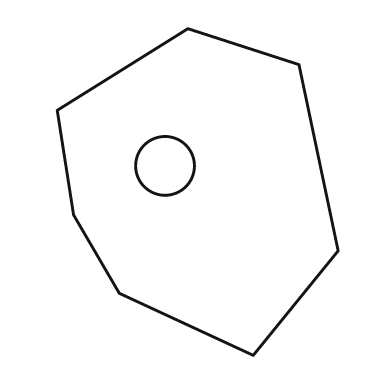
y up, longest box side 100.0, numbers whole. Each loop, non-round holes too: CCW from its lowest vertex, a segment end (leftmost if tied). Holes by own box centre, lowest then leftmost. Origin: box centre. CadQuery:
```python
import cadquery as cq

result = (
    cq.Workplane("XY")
    .moveTo(17.0, -50.0)
    .lineTo(43.0, -18.0)
    .lineTo(31.0, 39.0)
    .lineTo(-3.0, 50.0)
    .lineTo(-43.0, 25.0)
    .lineTo(-38.0, -7.0)
    .lineTo(-24.0, -31.0)
    .close()
    .moveTo(-10.0, 8.0)
    .circle(9.0)
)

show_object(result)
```